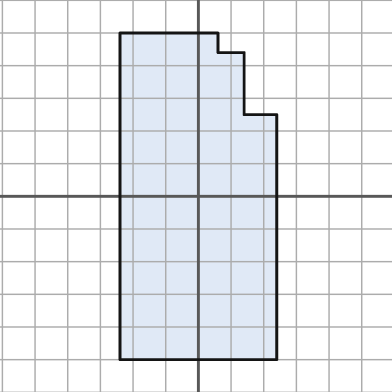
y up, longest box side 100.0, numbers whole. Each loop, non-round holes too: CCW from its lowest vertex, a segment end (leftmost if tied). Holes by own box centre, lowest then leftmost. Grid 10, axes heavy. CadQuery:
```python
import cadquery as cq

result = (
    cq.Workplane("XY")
    .moveTo(-24.0, -50.0)
    .lineTo(24.0, -50.0)
    .lineTo(24.0, 25.0)
    .lineTo(14.0, 25.0)
    .lineTo(14.0, 44.0)
    .lineTo(6.0, 44.0)
    .lineTo(6.0, 50.0)
    .lineTo(-24.0, 50.0)
    .close()
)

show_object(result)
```